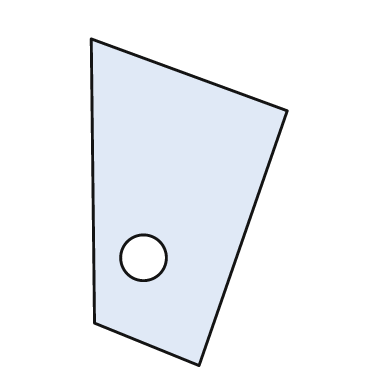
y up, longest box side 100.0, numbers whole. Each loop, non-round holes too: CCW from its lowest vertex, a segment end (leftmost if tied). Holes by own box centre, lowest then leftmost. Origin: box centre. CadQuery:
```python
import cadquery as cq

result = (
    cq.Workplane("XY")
    .moveTo(3.0, -50.0)
    .lineTo(30.0, 28.0)
    .lineTo(-30.0, 50.0)
    .lineTo(-29.0, -37.0)
    .close()
    .moveTo(-14.0, -17.0)
    .circle(7.0)
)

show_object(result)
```